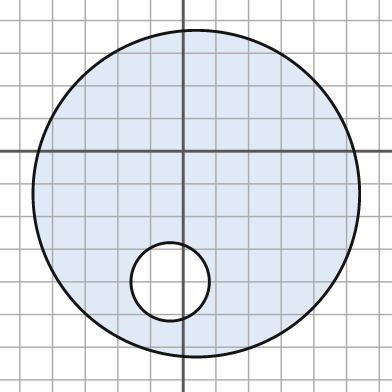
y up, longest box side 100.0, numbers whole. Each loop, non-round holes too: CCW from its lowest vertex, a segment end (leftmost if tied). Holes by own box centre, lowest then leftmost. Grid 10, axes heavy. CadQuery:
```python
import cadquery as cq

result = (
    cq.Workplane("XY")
    .moveTo(4.0, -13.0)
    .circle(50.0)
    .moveTo(-4.0, -40.0)
    .circle(12.0)
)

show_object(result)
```